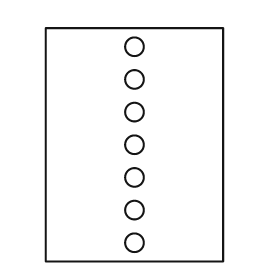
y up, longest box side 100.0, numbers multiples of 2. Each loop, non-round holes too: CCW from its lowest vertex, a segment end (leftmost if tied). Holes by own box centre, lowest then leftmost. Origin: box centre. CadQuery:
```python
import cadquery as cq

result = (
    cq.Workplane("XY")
    .moveTo(-38.0, -50.0)
    .lineTo(38.0, -50.0)
    .lineTo(38.0, 50.0)
    .lineTo(-38.0, 50.0)
    .close()
    .moveTo(0.0, -42.0)
    .circle(4.0)
    .moveTo(0.0, -28.0)
    .circle(4.0)
    .moveTo(0.0, -14.0)
    .circle(4.0)
    .moveTo(0.0, 0.0)
    .circle(4.0)
    .moveTo(0.0, 14.0)
    .circle(4.0)
    .moveTo(0.0, 28.0)
    .circle(4.0)
    .moveTo(0.0, 42.0)
    .circle(4.0)
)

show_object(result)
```